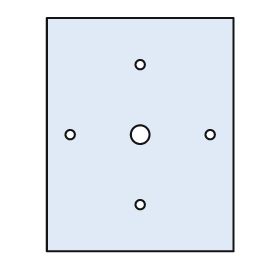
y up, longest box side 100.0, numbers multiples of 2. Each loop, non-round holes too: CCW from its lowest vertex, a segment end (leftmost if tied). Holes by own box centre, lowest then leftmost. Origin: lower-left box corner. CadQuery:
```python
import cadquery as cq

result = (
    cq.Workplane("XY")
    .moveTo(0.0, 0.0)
    .lineTo(80.0, 0.0)
    .lineTo(80.0, 100.0)
    .lineTo(0.0, 100.0)
    .close()
    .moveTo(40.0, 20.0)
    .circle(2.0)
    .moveTo(10.0, 50.0)
    .circle(2.0)
    .moveTo(40.0, 50.0)
    .circle(4.0)
    .moveTo(70.0, 50.0)
    .circle(2.0)
    .moveTo(40.0, 80.0)
    .circle(2.0)
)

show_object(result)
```